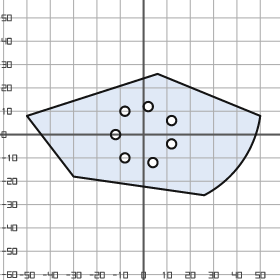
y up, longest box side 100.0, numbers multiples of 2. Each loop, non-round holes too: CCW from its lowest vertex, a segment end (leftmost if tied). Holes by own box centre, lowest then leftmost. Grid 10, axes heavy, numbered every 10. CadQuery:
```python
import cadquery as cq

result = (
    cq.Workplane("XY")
    .moveTo(26.0, -26.0)
    .threePointArc((42.0, -12.0), (50.0, 8.0))
    .lineTo(6.0, 26.0)
    .lineTo(-50.0, 8.0)
    .lineTo(-30.0, -18.0)
    .close()
    .moveTo(4.0, -12.0)
    .circle(2.0)
    .moveTo(-8.0, -10.0)
    .circle(2.0)
    .moveTo(12.0, -4.0)
    .circle(2.0)
    .moveTo(-12.0, 0.0)
    .circle(2.0)
    .moveTo(12.0, 6.0)
    .circle(2.0)
    .moveTo(-8.0, 10.0)
    .circle(2.0)
    .moveTo(2.0, 12.0)
    .circle(2.0)
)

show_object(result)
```